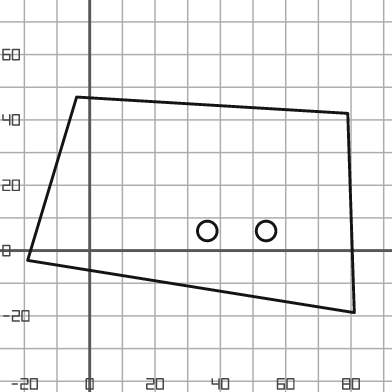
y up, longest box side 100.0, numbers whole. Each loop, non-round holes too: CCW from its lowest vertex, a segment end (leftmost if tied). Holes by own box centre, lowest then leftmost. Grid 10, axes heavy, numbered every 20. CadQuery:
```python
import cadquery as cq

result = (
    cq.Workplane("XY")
    .moveTo(81.0, -19.0)
    .lineTo(79.0, 42.0)
    .lineTo(-4.0, 47.0)
    .lineTo(-19.0, -3.0)
    .close()
    .moveTo(36.0, 6.0)
    .circle(3.0)
    .moveTo(54.0, 6.0)
    .circle(3.0)
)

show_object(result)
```